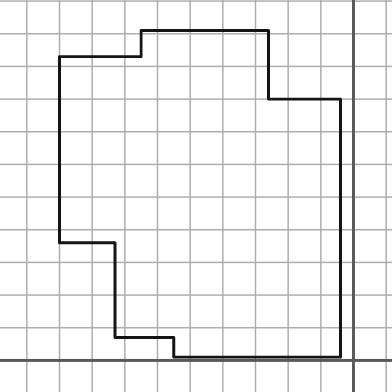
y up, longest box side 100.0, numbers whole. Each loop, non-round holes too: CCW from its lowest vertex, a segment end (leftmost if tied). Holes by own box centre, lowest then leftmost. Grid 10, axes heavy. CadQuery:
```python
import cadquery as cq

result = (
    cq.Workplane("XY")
    .moveTo(-55.0, 1.0)
    .lineTo(-4.0, 1.0)
    .lineTo(-4.0, 80.0)
    .lineTo(-26.0, 80.0)
    .lineTo(-26.0, 101.0)
    .lineTo(-65.0, 101.0)
    .lineTo(-65.0, 93.0)
    .lineTo(-90.0, 93.0)
    .lineTo(-90.0, 36.0)
    .lineTo(-73.0, 36.0)
    .lineTo(-73.0, 7.0)
    .lineTo(-55.0, 7.0)
    .close()
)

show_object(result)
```